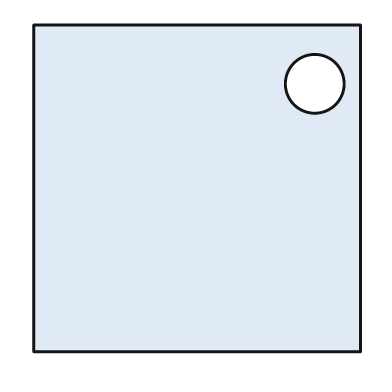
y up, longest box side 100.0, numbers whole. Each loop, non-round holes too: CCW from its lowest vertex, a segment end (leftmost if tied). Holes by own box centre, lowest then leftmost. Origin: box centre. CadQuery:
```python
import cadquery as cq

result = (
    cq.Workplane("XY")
    .moveTo(-50.0, -50.0)
    .lineTo(50.0, -50.0)
    .lineTo(50.0, 50.0)
    .lineTo(-50.0, 50.0)
    .close()
    .moveTo(36.0, 32.0)
    .circle(9.0)
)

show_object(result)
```